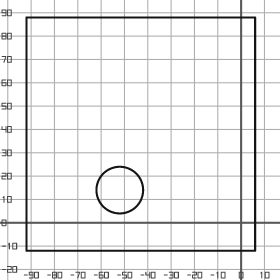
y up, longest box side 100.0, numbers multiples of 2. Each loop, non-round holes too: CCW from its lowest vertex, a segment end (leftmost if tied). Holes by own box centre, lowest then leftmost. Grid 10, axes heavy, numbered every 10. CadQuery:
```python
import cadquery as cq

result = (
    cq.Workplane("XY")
    .moveTo(-92.0, -12.0)
    .lineTo(6.0, -12.0)
    .lineTo(6.0, 88.0)
    .lineTo(-92.0, 88.0)
    .close()
    .moveTo(-52.0, 14.0)
    .circle(10.0)
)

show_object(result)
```